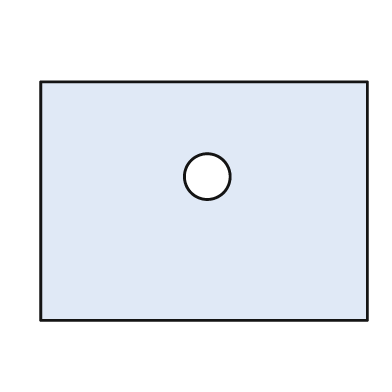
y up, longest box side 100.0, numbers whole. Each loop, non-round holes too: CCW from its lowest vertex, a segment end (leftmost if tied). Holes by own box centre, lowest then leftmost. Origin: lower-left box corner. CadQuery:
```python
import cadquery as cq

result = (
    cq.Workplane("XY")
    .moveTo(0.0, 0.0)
    .lineTo(100.0, 0.0)
    .lineTo(100.0, 73.0)
    .lineTo(0.0, 73.0)
    .close()
    .moveTo(51.0, 44.0)
    .circle(7.0)
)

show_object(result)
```